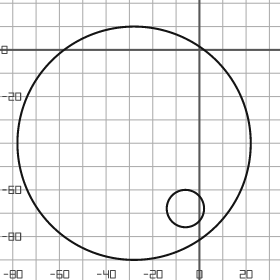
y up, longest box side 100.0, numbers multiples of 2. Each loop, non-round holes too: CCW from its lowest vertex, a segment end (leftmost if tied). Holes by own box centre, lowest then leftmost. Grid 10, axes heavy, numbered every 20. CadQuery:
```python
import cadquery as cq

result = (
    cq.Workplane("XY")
    .moveTo(-28.0, -40.0)
    .circle(50.0)
    .moveTo(-6.0, -68.0)
    .circle(8.0)
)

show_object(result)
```